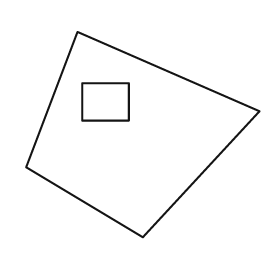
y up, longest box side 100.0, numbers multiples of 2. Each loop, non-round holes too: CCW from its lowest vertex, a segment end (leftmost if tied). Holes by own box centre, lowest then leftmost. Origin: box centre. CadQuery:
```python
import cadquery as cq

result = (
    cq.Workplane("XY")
    .moveTo(0.0, -44.0)
    .lineTo(50.0, 10.0)
    .lineTo(-28.0, 44.0)
    .lineTo(-50.0, -14.0)
    .close()
    .moveTo(-26.0, 6.0)
    .lineTo(-6.0, 6.0)
    .lineTo(-6.0, 22.0)
    .lineTo(-26.0, 22.0)
    .close()
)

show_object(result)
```